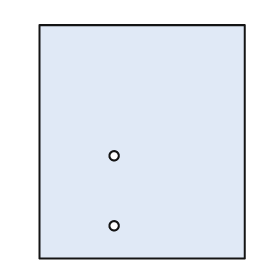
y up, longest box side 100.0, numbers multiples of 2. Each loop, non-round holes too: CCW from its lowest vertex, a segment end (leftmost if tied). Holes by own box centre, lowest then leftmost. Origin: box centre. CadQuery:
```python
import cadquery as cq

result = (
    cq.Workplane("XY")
    .moveTo(-44.0, -50.0)
    .lineTo(44.0, -50.0)
    .lineTo(44.0, 50.0)
    .lineTo(-44.0, 50.0)
    .close()
    .moveTo(-12.0, -36.0)
    .circle(2.0)
    .moveTo(-12.0, -6.0)
    .circle(2.0)
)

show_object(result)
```